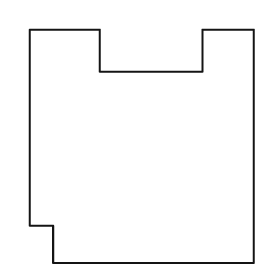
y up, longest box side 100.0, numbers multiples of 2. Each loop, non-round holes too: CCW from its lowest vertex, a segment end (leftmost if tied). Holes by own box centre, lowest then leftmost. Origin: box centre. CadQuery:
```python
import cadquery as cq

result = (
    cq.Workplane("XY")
    .moveTo(-38.0, -50.0)
    .lineTo(48.0, -50.0)
    .lineTo(48.0, 50.0)
    .lineTo(26.0, 50.0)
    .lineTo(26.0, 32.0)
    .lineTo(-18.0, 32.0)
    .lineTo(-18.0, 50.0)
    .lineTo(-48.0, 50.0)
    .lineTo(-48.0, -34.0)
    .lineTo(-38.0, -34.0)
    .close()
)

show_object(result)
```